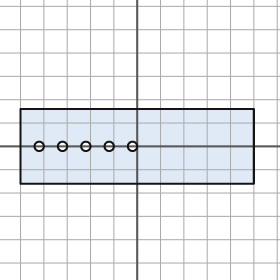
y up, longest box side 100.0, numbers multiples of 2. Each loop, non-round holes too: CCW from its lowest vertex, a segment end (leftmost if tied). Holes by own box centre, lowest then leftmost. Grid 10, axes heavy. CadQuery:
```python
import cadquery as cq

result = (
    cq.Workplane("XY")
    .moveTo(-50.0, -16.0)
    .lineTo(50.0, -16.0)
    .lineTo(50.0, 16.0)
    .lineTo(-50.0, 16.0)
    .close()
    .moveTo(-42.0, 0.0)
    .circle(2.0)
    .moveTo(-32.0, 0.0)
    .circle(2.0)
    .moveTo(-22.0, 0.0)
    .circle(2.0)
    .moveTo(-12.0, 0.0)
    .circle(2.0)
    .moveTo(-2.0, 0.0)
    .circle(2.0)
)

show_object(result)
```